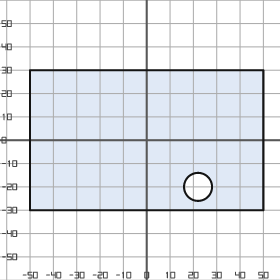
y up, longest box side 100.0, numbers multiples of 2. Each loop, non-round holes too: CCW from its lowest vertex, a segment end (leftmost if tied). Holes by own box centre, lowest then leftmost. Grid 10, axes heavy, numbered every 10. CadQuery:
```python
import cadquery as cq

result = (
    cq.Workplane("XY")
    .moveTo(-50.0, -30.0)
    .lineTo(50.0, -30.0)
    .lineTo(50.0, 30.0)
    .lineTo(-50.0, 30.0)
    .close()
    .moveTo(22.0, -20.0)
    .circle(6.0)
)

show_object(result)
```